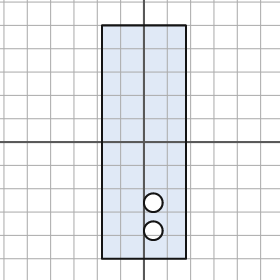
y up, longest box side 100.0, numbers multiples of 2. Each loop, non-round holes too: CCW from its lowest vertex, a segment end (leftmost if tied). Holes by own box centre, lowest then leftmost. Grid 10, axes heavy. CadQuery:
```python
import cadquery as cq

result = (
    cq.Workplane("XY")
    .moveTo(-18.0, -50.0)
    .lineTo(18.0, -50.0)
    .lineTo(18.0, 50.0)
    .lineTo(-18.0, 50.0)
    .close()
    .moveTo(4.0, -38.0)
    .circle(4.0)
    .moveTo(4.0, -26.0)
    .circle(4.0)
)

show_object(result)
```